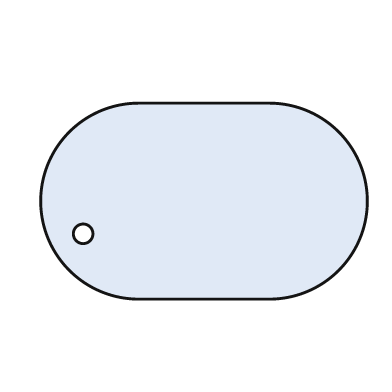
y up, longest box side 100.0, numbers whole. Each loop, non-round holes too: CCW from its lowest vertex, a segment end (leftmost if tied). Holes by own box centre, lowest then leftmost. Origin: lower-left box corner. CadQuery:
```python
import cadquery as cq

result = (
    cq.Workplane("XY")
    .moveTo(30.0, 0.0)
    .lineTo(70.0, 0.0)
    .threePointArc((100.0, 30.0), (70.0, 60.0))
    .lineTo(30.0, 60.0)
    .threePointArc((0.0, 30.0), (30.0, 0.0))
    .close()
    .moveTo(13.0, 20.0)
    .circle(3.0)
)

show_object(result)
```